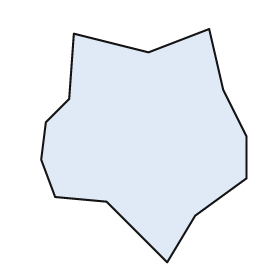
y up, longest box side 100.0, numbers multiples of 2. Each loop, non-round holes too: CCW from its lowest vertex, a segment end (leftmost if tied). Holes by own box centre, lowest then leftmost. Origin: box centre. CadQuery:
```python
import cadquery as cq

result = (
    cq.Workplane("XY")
    .moveTo(10.0, -50.0)
    .lineTo(22.0, -30.0)
    .lineTo(44.0, -14.0)
    .lineTo(44.0, 4.0)
    .lineTo(34.0, 24.0)
    .lineTo(28.0, 50.0)
    .lineTo(2.0, 40.0)
    .lineTo(-30.0, 48.0)
    .lineTo(-32.0, 20.0)
    .lineTo(-42.0, 10.0)
    .lineTo(-44.0, -6.0)
    .lineTo(-38.0, -22.0)
    .lineTo(-16.0, -24.0)
    .close()
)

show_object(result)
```